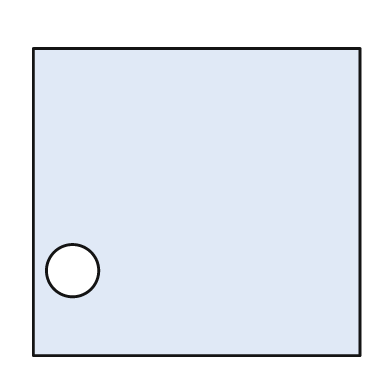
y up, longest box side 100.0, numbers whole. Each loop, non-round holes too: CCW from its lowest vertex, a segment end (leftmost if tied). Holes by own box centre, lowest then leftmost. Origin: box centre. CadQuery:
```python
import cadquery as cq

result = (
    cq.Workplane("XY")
    .moveTo(-50.0, -47.0)
    .lineTo(50.0, -47.0)
    .lineTo(50.0, 47.0)
    .lineTo(-50.0, 47.0)
    .close()
    .moveTo(-38.0, -21.0)
    .circle(8.0)
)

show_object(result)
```